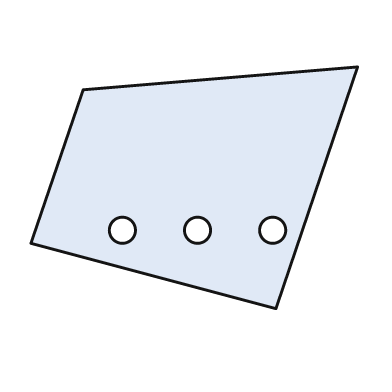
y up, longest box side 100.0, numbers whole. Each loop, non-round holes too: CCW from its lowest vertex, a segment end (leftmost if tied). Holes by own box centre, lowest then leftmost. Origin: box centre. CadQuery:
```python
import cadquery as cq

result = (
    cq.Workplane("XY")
    .moveTo(25.0, -37.0)
    .lineTo(50.0, 37.0)
    .lineTo(-34.0, 30.0)
    .lineTo(-50.0, -17.0)
    .close()
    .moveTo(-22.0, -13.0)
    .circle(4.0)
    .moveTo(1.0, -13.0)
    .circle(4.0)
    .moveTo(24.0, -13.0)
    .circle(4.0)
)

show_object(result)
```